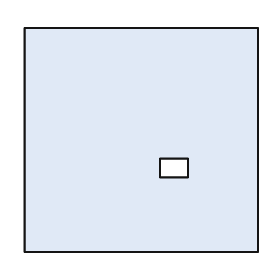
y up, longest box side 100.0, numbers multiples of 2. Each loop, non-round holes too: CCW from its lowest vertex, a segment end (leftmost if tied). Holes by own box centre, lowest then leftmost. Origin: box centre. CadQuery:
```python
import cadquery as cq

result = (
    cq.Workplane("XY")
    .moveTo(-50.0, -48.0)
    .lineTo(50.0, -48.0)
    .lineTo(50.0, 48.0)
    .lineTo(-50.0, 48.0)
    .close()
    .moveTo(8.0, -16.0)
    .lineTo(20.0, -16.0)
    .lineTo(20.0, -8.0)
    .lineTo(8.0, -8.0)
    .close()
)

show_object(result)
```